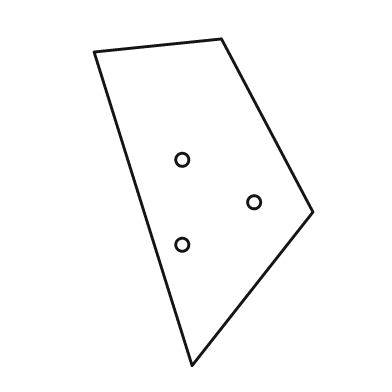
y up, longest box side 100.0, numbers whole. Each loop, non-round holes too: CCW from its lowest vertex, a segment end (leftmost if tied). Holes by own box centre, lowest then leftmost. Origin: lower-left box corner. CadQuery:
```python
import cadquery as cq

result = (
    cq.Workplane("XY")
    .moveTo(30.0, 0.0)
    .lineTo(67.0, 47.0)
    .lineTo(39.0, 100.0)
    .lineTo(0.0, 96.0)
    .close()
    .moveTo(27.0, 37.0)
    .circle(2.0)
    .moveTo(49.0, 50.0)
    .circle(2.0)
    .moveTo(27.0, 63.0)
    .circle(2.0)
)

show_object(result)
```